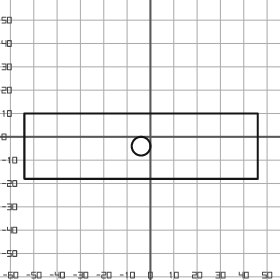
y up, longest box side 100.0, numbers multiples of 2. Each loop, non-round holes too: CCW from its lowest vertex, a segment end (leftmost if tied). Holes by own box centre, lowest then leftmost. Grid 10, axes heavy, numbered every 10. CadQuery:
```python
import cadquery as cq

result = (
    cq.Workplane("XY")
    .moveTo(-54.0, -18.0)
    .lineTo(46.0, -18.0)
    .lineTo(46.0, 10.0)
    .lineTo(-54.0, 10.0)
    .close()
    .moveTo(-4.0, -4.0)
    .circle(4.0)
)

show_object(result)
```